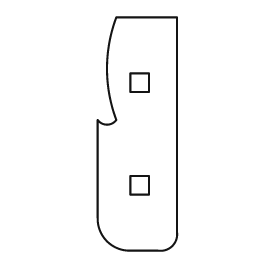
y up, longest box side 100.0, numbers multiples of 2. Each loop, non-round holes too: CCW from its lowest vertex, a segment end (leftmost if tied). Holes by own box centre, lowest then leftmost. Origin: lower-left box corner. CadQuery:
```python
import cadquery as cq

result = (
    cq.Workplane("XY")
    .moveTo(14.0, 0.0)
    .lineTo(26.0, 0.0)
    .threePointArc((32.0, 2.0), (34.0, 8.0))
    .lineTo(34.0, 100.0)
    .lineTo(8.0, 100.0)
    .threePointArc((4.0, 78.0), (8.0, 56.0))
    .threePointArc((4.0, 54.0), (0.0, 56.0))
    .lineTo(0.0, 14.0)
    .threePointArc((4.0, 4.0), (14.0, 0.0))
    .close()
    .moveTo(14.0, 24.0)
    .lineTo(22.0, 24.0)
    .lineTo(22.0, 32.0)
    .lineTo(14.0, 32.0)
    .close()
    .moveTo(14.0, 68.0)
    .lineTo(22.0, 68.0)
    .lineTo(22.0, 76.0)
    .lineTo(14.0, 76.0)
    .close()
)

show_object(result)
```